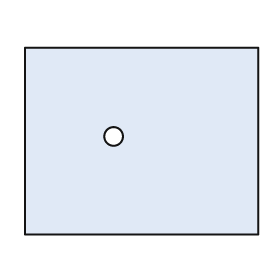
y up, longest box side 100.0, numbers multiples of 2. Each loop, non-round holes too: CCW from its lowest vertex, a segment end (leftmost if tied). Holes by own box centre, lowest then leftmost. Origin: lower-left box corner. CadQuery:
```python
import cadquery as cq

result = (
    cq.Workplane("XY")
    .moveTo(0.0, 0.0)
    .lineTo(100.0, 0.0)
    .lineTo(100.0, 80.0)
    .lineTo(0.0, 80.0)
    .close()
    .moveTo(38.0, 42.0)
    .circle(4.0)
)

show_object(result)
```